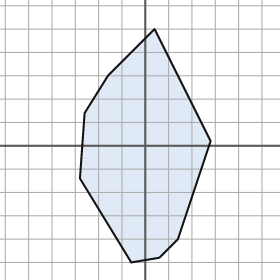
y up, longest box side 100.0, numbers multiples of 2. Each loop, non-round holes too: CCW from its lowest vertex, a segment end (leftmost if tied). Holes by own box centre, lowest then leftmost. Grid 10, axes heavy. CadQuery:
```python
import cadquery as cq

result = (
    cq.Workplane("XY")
    .moveTo(-6.0, -50.0)
    .lineTo(6.0, -48.0)
    .lineTo(14.0, -40.0)
    .lineTo(28.0, 2.0)
    .lineTo(4.0, 50.0)
    .lineTo(-16.0, 30.0)
    .lineTo(-26.0, 14.0)
    .lineTo(-28.0, -14.0)
    .close()
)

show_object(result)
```